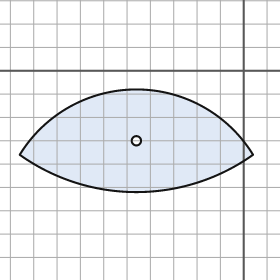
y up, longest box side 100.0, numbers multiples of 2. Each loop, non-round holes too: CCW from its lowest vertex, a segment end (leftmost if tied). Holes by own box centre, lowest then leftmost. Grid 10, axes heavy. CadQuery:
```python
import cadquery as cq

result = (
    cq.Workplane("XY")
    .moveTo(-96.0, -36.0)
    .threePointArc((-46.0, -52.0), (4.0, -36.0))
    .threePointArc((-46.0, -8.0), (-96.0, -36.0))
    .close()
    .moveTo(-46.0, -30.0)
    .circle(2.0)
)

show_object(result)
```